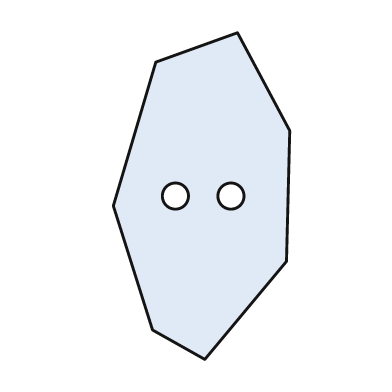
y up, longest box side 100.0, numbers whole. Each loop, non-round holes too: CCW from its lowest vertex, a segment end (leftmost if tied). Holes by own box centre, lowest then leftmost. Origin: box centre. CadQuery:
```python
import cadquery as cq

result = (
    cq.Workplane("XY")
    .moveTo(1.0, -50.0)
    .lineTo(26.0, -20.0)
    .lineTo(27.0, 20.0)
    .lineTo(11.0, 50.0)
    .lineTo(-14.0, 41.0)
    .lineTo(-27.0, -3.0)
    .lineTo(-15.0, -41.0)
    .close()
    .moveTo(-8.0, 0.0)
    .circle(4.0)
    .moveTo(9.0, 0.0)
    .circle(4.0)
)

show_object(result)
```